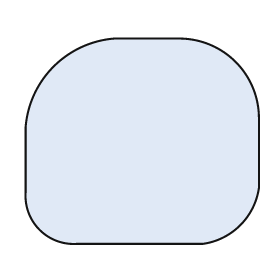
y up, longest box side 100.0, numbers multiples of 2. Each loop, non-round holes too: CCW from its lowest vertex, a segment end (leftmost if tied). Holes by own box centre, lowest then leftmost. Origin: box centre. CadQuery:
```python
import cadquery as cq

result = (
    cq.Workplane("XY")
    .moveTo(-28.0, -44.0)
    .lineTo(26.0, -44.0)
    .threePointArc((42.0, -36.0), (50.0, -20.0))
    .lineTo(50.0, 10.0)
    .threePointArc((40.0, 34.0), (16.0, 44.0))
    .lineTo(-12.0, 44.0)
    .threePointArc((-38.0, 32.0), (-50.0, 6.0))
    .lineTo(-50.0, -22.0)
    .threePointArc((-44.0, -38.0), (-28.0, -44.0))
    .close()
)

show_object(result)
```